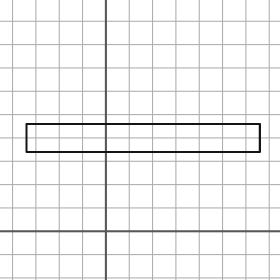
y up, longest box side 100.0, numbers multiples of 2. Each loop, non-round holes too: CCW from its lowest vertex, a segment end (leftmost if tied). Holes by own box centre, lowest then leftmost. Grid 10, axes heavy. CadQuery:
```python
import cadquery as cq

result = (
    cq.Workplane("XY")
    .moveTo(-34.0, 34.0)
    .lineTo(66.0, 34.0)
    .lineTo(66.0, 46.0)
    .lineTo(-34.0, 46.0)
    .close()
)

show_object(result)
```